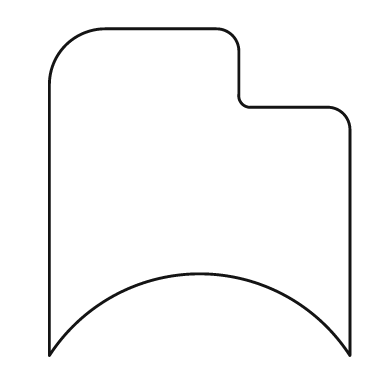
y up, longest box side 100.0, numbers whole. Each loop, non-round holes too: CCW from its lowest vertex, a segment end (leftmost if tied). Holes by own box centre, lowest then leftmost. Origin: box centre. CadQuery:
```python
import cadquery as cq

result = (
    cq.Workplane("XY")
    .moveTo(-46.0, -50.0)
    .threePointArc((0.0, -25.0), (46.0, -50.0))
    .lineTo(46.0, 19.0)
    .threePointArc((44.0, 24.0), (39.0, 26.0))
    .lineTo(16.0, 26.0)
    .threePointArc((13.0, 27.0), (12.0, 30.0))
    .lineTo(12.0, 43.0)
    .threePointArc((10.0, 48.0), (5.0, 50.0))
    .lineTo(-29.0, 50.0)
    .threePointArc((-41.0, 45.0), (-46.0, 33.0))
    .close()
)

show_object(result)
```